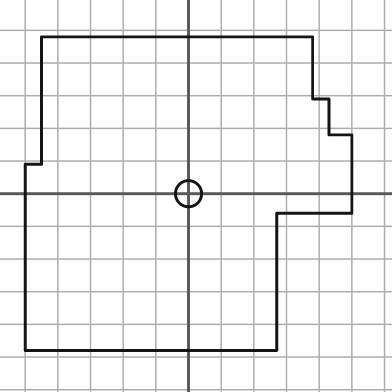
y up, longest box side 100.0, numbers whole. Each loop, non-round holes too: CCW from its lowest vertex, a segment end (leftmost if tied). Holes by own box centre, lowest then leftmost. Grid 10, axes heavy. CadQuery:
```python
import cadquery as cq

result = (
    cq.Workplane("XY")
    .moveTo(-50.0, -48.0)
    .lineTo(27.0, -48.0)
    .lineTo(27.0, -6.0)
    .lineTo(50.0, -6.0)
    .lineTo(50.0, 18.0)
    .lineTo(43.0, 18.0)
    .lineTo(43.0, 29.0)
    .lineTo(38.0, 29.0)
    .lineTo(38.0, 48.0)
    .lineTo(-45.0, 48.0)
    .lineTo(-45.0, 9.0)
    .lineTo(-50.0, 9.0)
    .close()
    .moveTo(0.0, 0.0)
    .circle(4.0)
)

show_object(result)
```